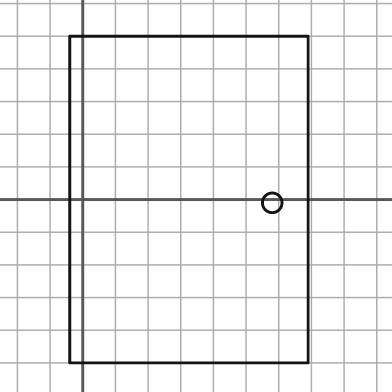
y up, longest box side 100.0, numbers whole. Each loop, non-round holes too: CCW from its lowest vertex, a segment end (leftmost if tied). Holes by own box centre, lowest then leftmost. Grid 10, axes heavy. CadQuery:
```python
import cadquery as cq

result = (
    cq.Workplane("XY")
    .moveTo(-4.0, -50.0)
    .lineTo(69.0, -50.0)
    .lineTo(69.0, 50.0)
    .lineTo(-4.0, 50.0)
    .close()
    .moveTo(58.0, -1.0)
    .circle(3.0)
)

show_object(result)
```